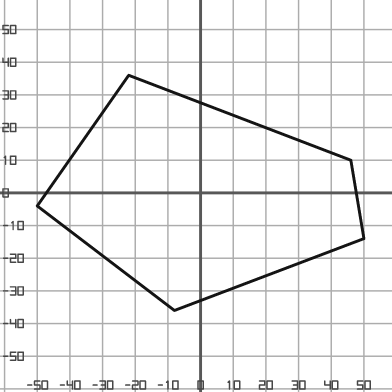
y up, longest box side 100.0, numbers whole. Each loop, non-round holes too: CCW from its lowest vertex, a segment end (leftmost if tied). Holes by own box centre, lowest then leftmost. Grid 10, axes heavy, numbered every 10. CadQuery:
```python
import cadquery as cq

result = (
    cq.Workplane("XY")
    .moveTo(-8.0, -36.0)
    .lineTo(50.0, -14.0)
    .lineTo(46.0, 10.0)
    .lineTo(-22.0, 36.0)
    .lineTo(-50.0, -4.0)
    .close()
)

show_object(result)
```